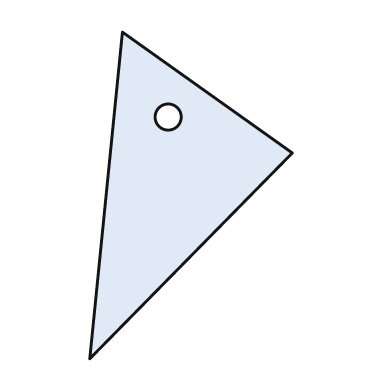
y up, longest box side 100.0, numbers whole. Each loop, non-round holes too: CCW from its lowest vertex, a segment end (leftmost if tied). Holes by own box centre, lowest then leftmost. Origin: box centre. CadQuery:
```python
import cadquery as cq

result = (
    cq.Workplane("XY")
    .moveTo(-31.0, -50.0)
    .lineTo(31.0, 13.0)
    .lineTo(-21.0, 50.0)
    .close()
    .moveTo(-7.0, 24.0)
    .circle(4.0)
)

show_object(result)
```